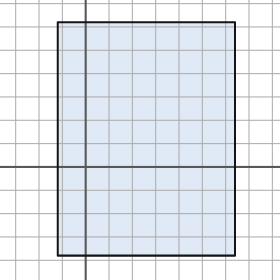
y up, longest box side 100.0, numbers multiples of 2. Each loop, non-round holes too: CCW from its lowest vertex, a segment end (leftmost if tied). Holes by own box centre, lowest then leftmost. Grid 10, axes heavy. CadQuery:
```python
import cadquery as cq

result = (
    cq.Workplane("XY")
    .moveTo(-12.0, -38.0)
    .lineTo(64.0, -38.0)
    .lineTo(64.0, 62.0)
    .lineTo(-12.0, 62.0)
    .close()
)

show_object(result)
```